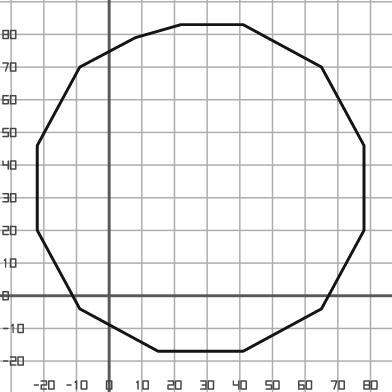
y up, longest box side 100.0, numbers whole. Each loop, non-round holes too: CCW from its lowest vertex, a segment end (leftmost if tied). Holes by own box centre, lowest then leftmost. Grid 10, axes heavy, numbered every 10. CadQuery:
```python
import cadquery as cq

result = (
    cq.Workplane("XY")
    .moveTo(15.0, -17.0)
    .lineTo(41.0, -17.0)
    .lineTo(65.0, -4.0)
    .lineTo(78.0, 20.0)
    .lineTo(78.0, 46.0)
    .lineTo(65.0, 70.0)
    .lineTo(41.0, 83.0)
    .lineTo(22.0, 83.0)
    .lineTo(8.0, 79.0)
    .lineTo(-9.0, 70.0)
    .lineTo(-22.0, 46.0)
    .lineTo(-22.0, 20.0)
    .lineTo(-9.0, -4.0)
    .close()
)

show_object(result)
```